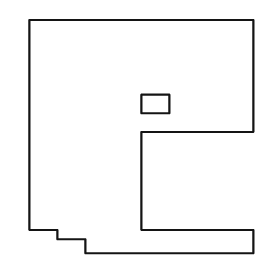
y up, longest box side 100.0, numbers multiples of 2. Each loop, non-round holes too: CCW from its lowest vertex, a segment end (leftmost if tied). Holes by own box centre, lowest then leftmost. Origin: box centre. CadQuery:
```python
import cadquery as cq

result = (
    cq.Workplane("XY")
    .moveTo(-24.0, -50.0)
    .lineTo(48.0, -50.0)
    .lineTo(48.0, -40.0)
    .lineTo(0.0, -40.0)
    .lineTo(0.0, 2.0)
    .lineTo(48.0, 2.0)
    .lineTo(48.0, 50.0)
    .lineTo(-48.0, 50.0)
    .lineTo(-48.0, -40.0)
    .lineTo(-36.0, -40.0)
    .lineTo(-36.0, -44.0)
    .lineTo(-24.0, -44.0)
    .close()
    .moveTo(0.0, 10.0)
    .lineTo(12.0, 10.0)
    .lineTo(12.0, 18.0)
    .lineTo(0.0, 18.0)
    .close()
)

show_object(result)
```